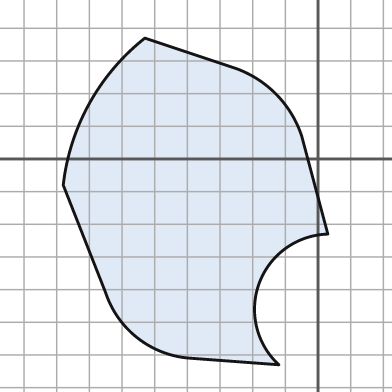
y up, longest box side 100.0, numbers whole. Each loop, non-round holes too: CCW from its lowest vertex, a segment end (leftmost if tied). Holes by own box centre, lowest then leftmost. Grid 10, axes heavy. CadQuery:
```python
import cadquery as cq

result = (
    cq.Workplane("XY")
    .moveTo(-12.0, -63.0)
    .threePointArc((-18.0, -38.0), (3.0, -23.0))
    .lineTo(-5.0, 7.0)
    .threePointArc((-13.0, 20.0), (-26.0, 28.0))
    .lineTo(-53.0, 37.0)
    .threePointArc((-70.0, 17.0), (-78.0, -8.0))
    .lineTo(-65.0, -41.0)
    .threePointArc((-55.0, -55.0), (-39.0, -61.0))
    .close()
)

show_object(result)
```